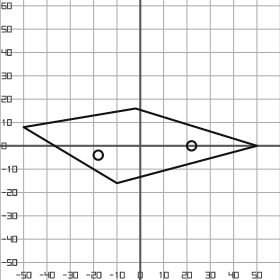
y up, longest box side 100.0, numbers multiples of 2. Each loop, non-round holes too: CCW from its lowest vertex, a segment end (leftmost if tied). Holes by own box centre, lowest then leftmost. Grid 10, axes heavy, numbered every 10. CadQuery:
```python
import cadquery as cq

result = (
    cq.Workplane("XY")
    .moveTo(-10.0, -16.0)
    .lineTo(50.0, 0.0)
    .lineTo(-2.0, 16.0)
    .lineTo(-50.0, 8.0)
    .close()
    .moveTo(-18.0, -4.0)
    .circle(2.0)
    .moveTo(22.0, 0.0)
    .circle(2.0)
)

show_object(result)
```